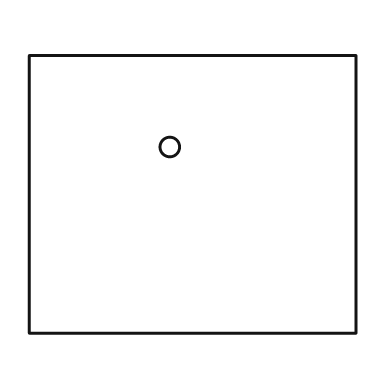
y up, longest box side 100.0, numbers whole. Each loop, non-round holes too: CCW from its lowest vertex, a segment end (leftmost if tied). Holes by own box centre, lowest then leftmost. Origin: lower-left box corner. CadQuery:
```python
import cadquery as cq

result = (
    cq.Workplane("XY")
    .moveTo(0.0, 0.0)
    .lineTo(100.0, 0.0)
    .lineTo(100.0, 85.0)
    .lineTo(0.0, 85.0)
    .close()
    .moveTo(43.0, 57.0)
    .circle(3.0)
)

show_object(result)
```